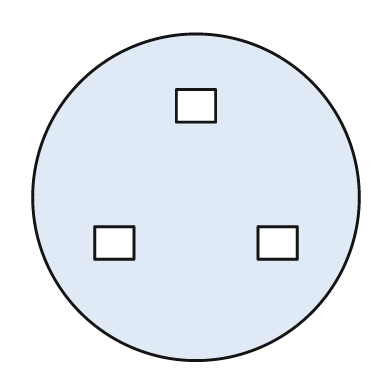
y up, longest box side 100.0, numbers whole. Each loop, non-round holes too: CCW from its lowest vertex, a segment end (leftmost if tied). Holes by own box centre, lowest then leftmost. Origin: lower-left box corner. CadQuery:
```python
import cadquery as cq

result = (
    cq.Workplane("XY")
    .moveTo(50.0, 50.0)
    .circle(50.0)
    .moveTo(19.0, 31.0)
    .lineTo(31.0, 31.0)
    .lineTo(31.0, 41.0)
    .lineTo(19.0, 41.0)
    .close()
    .moveTo(69.0, 31.0)
    .lineTo(81.0, 31.0)
    .lineTo(81.0, 41.0)
    .lineTo(69.0, 41.0)
    .close()
    .moveTo(44.0, 73.0)
    .lineTo(56.0, 73.0)
    .lineTo(56.0, 83.0)
    .lineTo(44.0, 83.0)
    .close()
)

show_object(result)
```